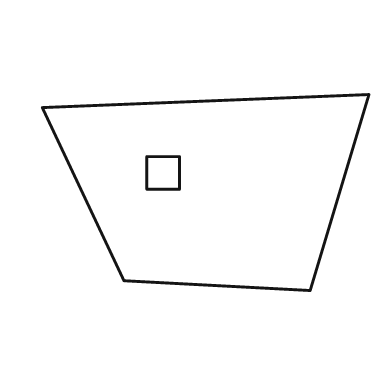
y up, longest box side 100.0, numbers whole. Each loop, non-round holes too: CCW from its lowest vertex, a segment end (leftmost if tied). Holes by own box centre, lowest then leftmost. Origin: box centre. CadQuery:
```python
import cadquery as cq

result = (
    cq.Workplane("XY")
    .moveTo(32.0, -30.0)
    .lineTo(50.0, 30.0)
    .lineTo(-50.0, 26.0)
    .lineTo(-25.0, -27.0)
    .close()
    .moveTo(-18.0, 1.0)
    .lineTo(-8.0, 1.0)
    .lineTo(-8.0, 11.0)
    .lineTo(-18.0, 11.0)
    .close()
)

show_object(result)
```